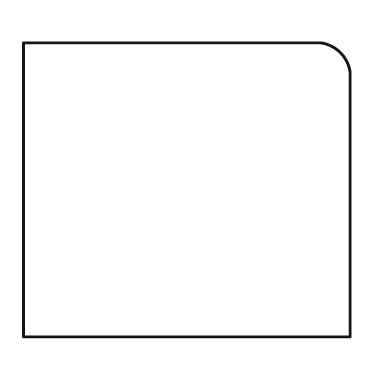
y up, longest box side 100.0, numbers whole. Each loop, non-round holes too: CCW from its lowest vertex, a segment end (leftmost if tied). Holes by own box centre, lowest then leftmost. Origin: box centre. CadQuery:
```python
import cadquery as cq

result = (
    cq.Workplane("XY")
    .moveTo(-50.0, -45.0)
    .lineTo(50.0, -45.0)
    .lineTo(50.0, 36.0)
    .threePointArc((47.0, 42.0), (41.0, 45.0))
    .lineTo(-50.0, 45.0)
    .close()
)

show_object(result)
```